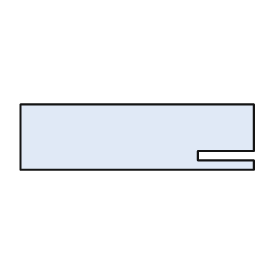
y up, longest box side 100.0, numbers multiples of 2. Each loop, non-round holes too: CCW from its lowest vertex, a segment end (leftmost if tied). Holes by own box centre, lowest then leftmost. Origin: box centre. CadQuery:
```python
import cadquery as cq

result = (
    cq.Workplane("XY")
    .moveTo(-50.0, -14.0)
    .lineTo(50.0, -14.0)
    .lineTo(50.0, -10.0)
    .lineTo(26.0, -10.0)
    .lineTo(26.0, -6.0)
    .lineTo(50.0, -6.0)
    .lineTo(50.0, 14.0)
    .lineTo(-50.0, 14.0)
    .close()
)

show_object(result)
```